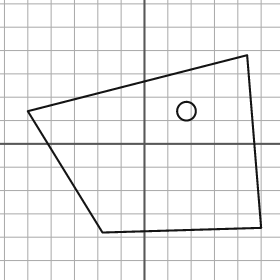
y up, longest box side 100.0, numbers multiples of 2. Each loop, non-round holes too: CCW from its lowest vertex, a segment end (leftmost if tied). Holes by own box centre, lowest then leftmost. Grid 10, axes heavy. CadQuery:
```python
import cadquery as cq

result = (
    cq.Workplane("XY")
    .moveTo(-18.0, -38.0)
    .lineTo(50.0, -36.0)
    .lineTo(44.0, 38.0)
    .lineTo(-50.0, 14.0)
    .close()
    .moveTo(18.0, 14.0)
    .circle(4.0)
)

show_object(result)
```